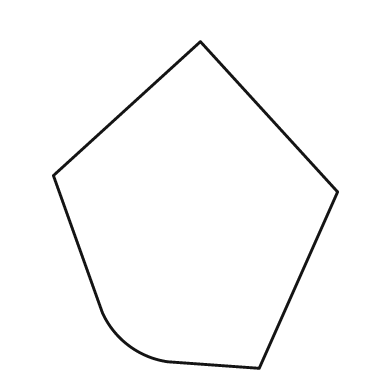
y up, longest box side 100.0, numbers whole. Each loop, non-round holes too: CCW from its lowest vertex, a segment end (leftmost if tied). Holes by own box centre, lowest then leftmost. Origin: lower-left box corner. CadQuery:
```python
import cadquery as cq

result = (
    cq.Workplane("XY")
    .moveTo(63.0, 0.0)
    .lineTo(87.0, 54.0)
    .lineTo(45.0, 100.0)
    .lineTo(0.0, 59.0)
    .lineTo(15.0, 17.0)
    .threePointArc((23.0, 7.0), (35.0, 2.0))
    .close()
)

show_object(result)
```